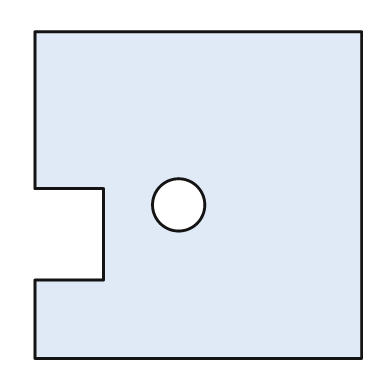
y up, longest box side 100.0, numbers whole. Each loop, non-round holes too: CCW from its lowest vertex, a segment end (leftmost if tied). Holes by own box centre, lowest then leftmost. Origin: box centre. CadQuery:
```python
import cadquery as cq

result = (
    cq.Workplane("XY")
    .moveTo(-50.0, -50.0)
    .lineTo(50.0, -50.0)
    .lineTo(50.0, 50.0)
    .lineTo(-50.0, 50.0)
    .lineTo(-50.0, 2.0)
    .lineTo(-29.0, 2.0)
    .lineTo(-29.0, -26.0)
    .lineTo(-50.0, -26.0)
    .close()
    .moveTo(-6.0, -3.0)
    .circle(8.0)
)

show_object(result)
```